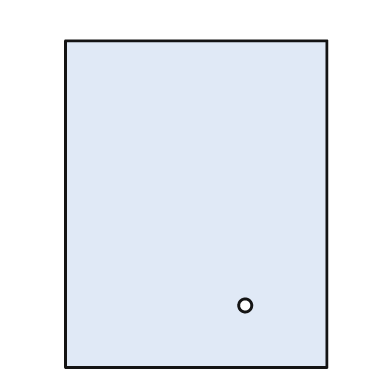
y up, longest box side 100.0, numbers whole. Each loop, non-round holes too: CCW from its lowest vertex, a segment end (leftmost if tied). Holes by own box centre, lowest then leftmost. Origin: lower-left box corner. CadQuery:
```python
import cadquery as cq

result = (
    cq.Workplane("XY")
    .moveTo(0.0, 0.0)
    .lineTo(80.0, 0.0)
    .lineTo(80.0, 100.0)
    .lineTo(0.0, 100.0)
    .close()
    .moveTo(55.0, 19.0)
    .circle(2.0)
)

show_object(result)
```